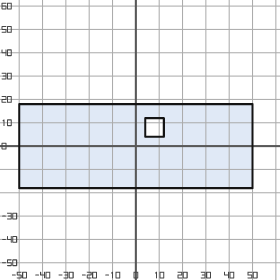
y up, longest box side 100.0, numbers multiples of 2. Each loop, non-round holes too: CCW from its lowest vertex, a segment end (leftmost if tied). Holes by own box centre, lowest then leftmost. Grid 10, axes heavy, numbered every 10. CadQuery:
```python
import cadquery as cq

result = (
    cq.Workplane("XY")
    .moveTo(-50.0, -18.0)
    .lineTo(50.0, -18.0)
    .lineTo(50.0, 18.0)
    .lineTo(-50.0, 18.0)
    .close()
    .moveTo(4.0, 4.0)
    .lineTo(12.0, 4.0)
    .lineTo(12.0, 12.0)
    .lineTo(4.0, 12.0)
    .close()
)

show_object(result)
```